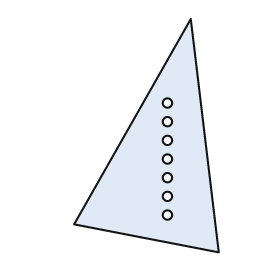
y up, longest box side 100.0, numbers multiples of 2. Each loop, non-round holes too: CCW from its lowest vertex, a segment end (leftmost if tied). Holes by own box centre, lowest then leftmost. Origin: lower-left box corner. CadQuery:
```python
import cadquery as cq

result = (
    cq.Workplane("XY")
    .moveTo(62.0, 0.0)
    .lineTo(50.0, 100.0)
    .lineTo(0.0, 12.0)
    .close()
    .moveTo(40.0, 16.0)
    .circle(2.0)
    .moveTo(40.0, 24.0)
    .circle(2.0)
    .moveTo(40.0, 32.0)
    .circle(2.0)
    .moveTo(40.0, 40.0)
    .circle(2.0)
    .moveTo(40.0, 48.0)
    .circle(2.0)
    .moveTo(40.0, 56.0)
    .circle(2.0)
    .moveTo(40.0, 64.0)
    .circle(2.0)
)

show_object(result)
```